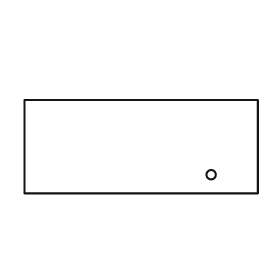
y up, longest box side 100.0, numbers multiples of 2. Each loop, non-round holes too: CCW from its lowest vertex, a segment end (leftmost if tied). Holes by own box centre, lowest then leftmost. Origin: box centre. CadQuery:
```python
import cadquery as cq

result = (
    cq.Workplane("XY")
    .moveTo(-50.0, -20.0)
    .lineTo(50.0, -20.0)
    .lineTo(50.0, 20.0)
    .lineTo(-50.0, 20.0)
    .close()
    .moveTo(30.0, -12.0)
    .circle(2.0)
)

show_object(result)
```